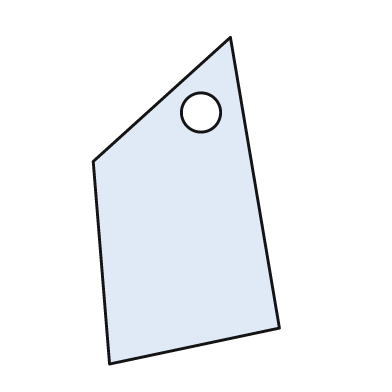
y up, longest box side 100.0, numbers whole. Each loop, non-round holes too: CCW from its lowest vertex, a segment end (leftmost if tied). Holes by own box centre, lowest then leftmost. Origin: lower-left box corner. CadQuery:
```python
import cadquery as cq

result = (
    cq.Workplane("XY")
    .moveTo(5.0, 0.0)
    .lineTo(57.0, 11.0)
    .lineTo(42.0, 100.0)
    .lineTo(0.0, 62.0)
    .close()
    .moveTo(33.0, 77.0)
    .circle(6.0)
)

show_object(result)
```